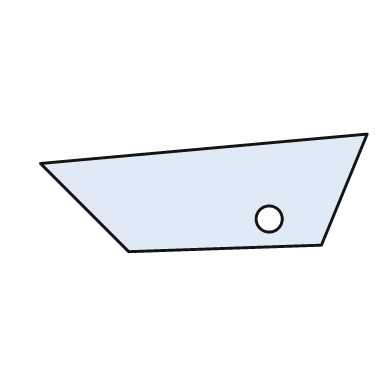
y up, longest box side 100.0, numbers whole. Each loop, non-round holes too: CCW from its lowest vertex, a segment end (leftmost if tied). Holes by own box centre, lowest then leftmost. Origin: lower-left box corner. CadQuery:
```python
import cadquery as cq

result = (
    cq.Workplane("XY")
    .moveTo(27.0, 0.0)
    .lineTo(86.0, 2.0)
    .lineTo(100.0, 36.0)
    .lineTo(0.0, 27.0)
    .close()
    .moveTo(70.0, 10.0)
    .circle(4.0)
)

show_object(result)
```